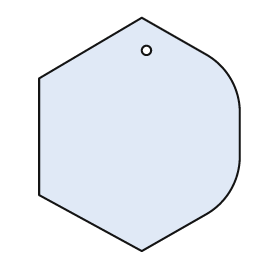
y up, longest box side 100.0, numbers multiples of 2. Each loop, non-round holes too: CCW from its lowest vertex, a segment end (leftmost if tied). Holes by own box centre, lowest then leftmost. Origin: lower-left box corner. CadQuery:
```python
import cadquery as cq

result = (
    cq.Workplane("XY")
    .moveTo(44.0, 0.0)
    .lineTo(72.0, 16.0)
    .threePointArc((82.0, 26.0), (86.0, 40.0))
    .lineTo(86.0, 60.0)
    .threePointArc((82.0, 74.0), (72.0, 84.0))
    .lineTo(44.0, 100.0)
    .lineTo(0.0, 74.0)
    .lineTo(0.0, 24.0)
    .close()
    .moveTo(46.0, 86.0)
    .circle(2.0)
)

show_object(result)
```